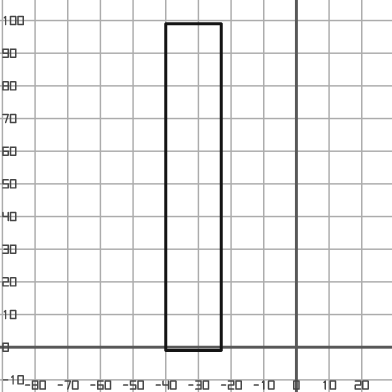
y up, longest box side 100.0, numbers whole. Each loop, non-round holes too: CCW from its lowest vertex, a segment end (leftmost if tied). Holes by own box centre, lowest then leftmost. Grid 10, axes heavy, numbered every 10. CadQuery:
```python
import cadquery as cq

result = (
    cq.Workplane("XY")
    .moveTo(-40.0, -1.0)
    .lineTo(-23.0, -1.0)
    .lineTo(-23.0, 99.0)
    .lineTo(-40.0, 99.0)
    .close()
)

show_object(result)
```